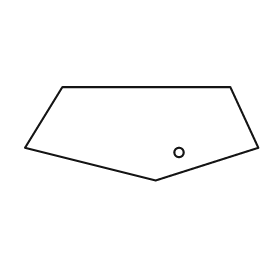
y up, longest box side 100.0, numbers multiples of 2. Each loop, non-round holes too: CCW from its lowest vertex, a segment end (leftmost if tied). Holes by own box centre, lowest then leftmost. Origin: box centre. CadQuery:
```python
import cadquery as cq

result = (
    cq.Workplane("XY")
    .moveTo(6.0, -20.0)
    .lineTo(50.0, -6.0)
    .lineTo(38.0, 20.0)
    .lineTo(-34.0, 20.0)
    .lineTo(-50.0, -6.0)
    .close()
    .moveTo(16.0, -8.0)
    .circle(2.0)
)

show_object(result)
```